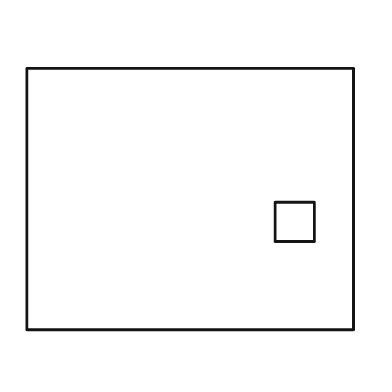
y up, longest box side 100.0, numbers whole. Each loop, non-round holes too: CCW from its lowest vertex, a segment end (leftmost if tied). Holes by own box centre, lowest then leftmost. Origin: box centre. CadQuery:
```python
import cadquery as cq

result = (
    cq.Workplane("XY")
    .moveTo(-50.0, -40.0)
    .lineTo(50.0, -40.0)
    .lineTo(50.0, 40.0)
    .lineTo(-50.0, 40.0)
    .close()
    .moveTo(26.0, -13.0)
    .lineTo(38.0, -13.0)
    .lineTo(38.0, -1.0)
    .lineTo(26.0, -1.0)
    .close()
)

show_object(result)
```